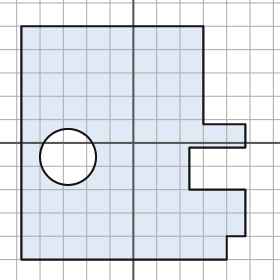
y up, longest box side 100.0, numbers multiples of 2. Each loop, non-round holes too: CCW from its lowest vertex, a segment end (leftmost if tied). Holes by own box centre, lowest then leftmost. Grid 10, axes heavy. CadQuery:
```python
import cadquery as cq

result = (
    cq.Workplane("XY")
    .moveTo(-48.0, -50.0)
    .lineTo(40.0, -50.0)
    .lineTo(40.0, -40.0)
    .lineTo(48.0, -40.0)
    .lineTo(48.0, -20.0)
    .lineTo(24.0, -20.0)
    .lineTo(24.0, -2.0)
    .lineTo(48.0, -2.0)
    .lineTo(48.0, 8.0)
    .lineTo(30.0, 8.0)
    .lineTo(30.0, 50.0)
    .lineTo(-48.0, 50.0)
    .close()
    .moveTo(-28.0, -6.0)
    .circle(12.0)
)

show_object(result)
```